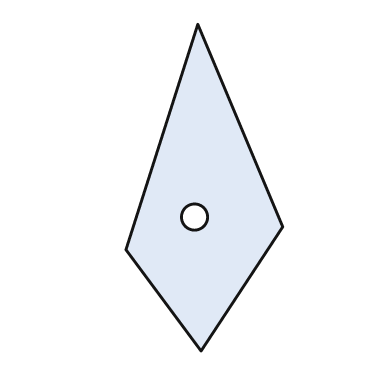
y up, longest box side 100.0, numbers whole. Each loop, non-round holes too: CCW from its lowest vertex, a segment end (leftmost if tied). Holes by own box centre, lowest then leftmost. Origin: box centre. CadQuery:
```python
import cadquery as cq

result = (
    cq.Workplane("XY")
    .moveTo(-1.0, -50.0)
    .lineTo(24.0, -12.0)
    .lineTo(-2.0, 50.0)
    .lineTo(-24.0, -19.0)
    .close()
    .moveTo(-3.0, -9.0)
    .circle(4.0)
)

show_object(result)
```